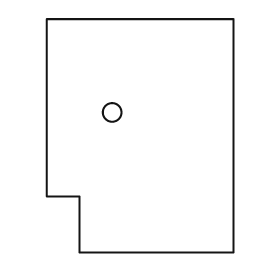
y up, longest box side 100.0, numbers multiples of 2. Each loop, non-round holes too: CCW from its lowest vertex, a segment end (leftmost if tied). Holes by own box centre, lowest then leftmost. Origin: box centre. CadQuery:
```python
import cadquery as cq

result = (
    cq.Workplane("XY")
    .moveTo(-26.0, -50.0)
    .lineTo(40.0, -50.0)
    .lineTo(40.0, 50.0)
    .lineTo(-40.0, 50.0)
    .lineTo(-40.0, -26.0)
    .lineTo(-26.0, -26.0)
    .close()
    .moveTo(-12.0, 10.0)
    .circle(4.0)
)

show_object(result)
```